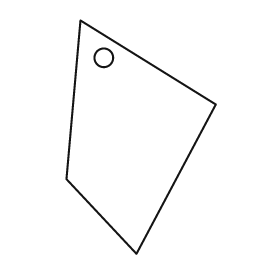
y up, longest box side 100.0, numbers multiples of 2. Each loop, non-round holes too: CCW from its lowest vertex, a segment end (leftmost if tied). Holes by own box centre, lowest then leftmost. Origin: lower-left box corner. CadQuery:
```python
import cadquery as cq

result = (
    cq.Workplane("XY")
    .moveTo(30.0, 0.0)
    .lineTo(64.0, 64.0)
    .lineTo(6.0, 100.0)
    .lineTo(0.0, 32.0)
    .close()
    .moveTo(16.0, 84.0)
    .circle(4.0)
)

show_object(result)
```